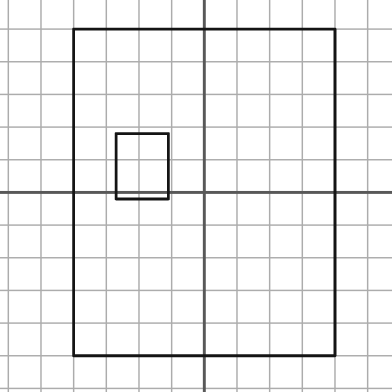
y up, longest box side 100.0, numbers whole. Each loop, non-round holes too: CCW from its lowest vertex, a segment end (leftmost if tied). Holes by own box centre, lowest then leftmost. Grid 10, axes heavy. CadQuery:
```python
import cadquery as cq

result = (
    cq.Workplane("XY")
    .moveTo(-40.0, -50.0)
    .lineTo(40.0, -50.0)
    .lineTo(40.0, 50.0)
    .lineTo(-40.0, 50.0)
    .close()
    .moveTo(-27.0, -2.0)
    .lineTo(-11.0, -2.0)
    .lineTo(-11.0, 18.0)
    .lineTo(-27.0, 18.0)
    .close()
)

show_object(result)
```